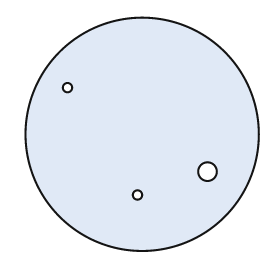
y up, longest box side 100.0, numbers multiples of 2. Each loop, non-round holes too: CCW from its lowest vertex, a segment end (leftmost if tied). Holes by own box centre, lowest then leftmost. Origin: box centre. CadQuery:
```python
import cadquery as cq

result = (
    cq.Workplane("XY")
    .moveTo(0.0, 0.0)
    .circle(50.0)
    .moveTo(-2.0, -26.0)
    .circle(2.0)
    .moveTo(28.0, -16.0)
    .circle(4.0)
    .moveTo(-32.0, 20.0)
    .circle(2.0)
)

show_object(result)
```